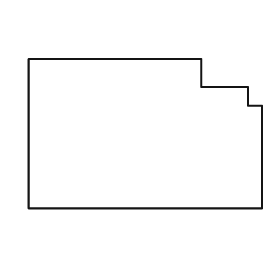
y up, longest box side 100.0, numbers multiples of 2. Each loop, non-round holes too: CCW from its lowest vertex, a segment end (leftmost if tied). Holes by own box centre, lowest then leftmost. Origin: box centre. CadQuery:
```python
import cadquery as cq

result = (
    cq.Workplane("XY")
    .moveTo(-50.0, -32.0)
    .lineTo(50.0, -32.0)
    .lineTo(50.0, 12.0)
    .lineTo(44.0, 12.0)
    .lineTo(44.0, 20.0)
    .lineTo(24.0, 20.0)
    .lineTo(24.0, 32.0)
    .lineTo(-50.0, 32.0)
    .close()
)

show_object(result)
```